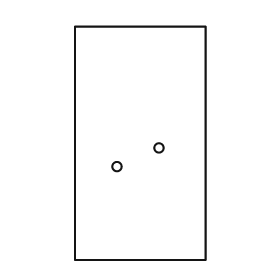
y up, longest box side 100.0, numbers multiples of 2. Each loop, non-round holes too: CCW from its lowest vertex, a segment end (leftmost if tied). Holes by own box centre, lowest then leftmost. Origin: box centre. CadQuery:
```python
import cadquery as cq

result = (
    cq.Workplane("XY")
    .moveTo(-28.0, -50.0)
    .lineTo(28.0, -50.0)
    .lineTo(28.0, 50.0)
    .lineTo(-28.0, 50.0)
    .close()
    .moveTo(-10.0, -10.0)
    .circle(2.0)
    .moveTo(8.0, -2.0)
    .circle(2.0)
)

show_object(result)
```